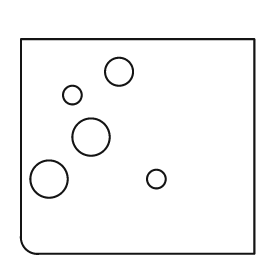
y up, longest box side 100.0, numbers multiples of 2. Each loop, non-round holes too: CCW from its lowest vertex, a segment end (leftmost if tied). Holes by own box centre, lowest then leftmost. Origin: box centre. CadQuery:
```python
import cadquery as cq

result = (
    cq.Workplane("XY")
    .moveTo(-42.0, -46.0)
    .lineTo(50.0, -46.0)
    .lineTo(50.0, 46.0)
    .lineTo(-50.0, 46.0)
    .lineTo(-50.0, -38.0)
    .threePointArc((-48.0, -44.0), (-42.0, -46.0))
    .close()
    .moveTo(-38.0, -14.0)
    .circle(8.0)
    .moveTo(8.0, -14.0)
    .circle(4.0)
    .moveTo(-20.0, 4.0)
    .circle(8.0)
    .moveTo(-28.0, 22.0)
    .circle(4.0)
    .moveTo(-8.0, 32.0)
    .circle(6.0)
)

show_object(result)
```